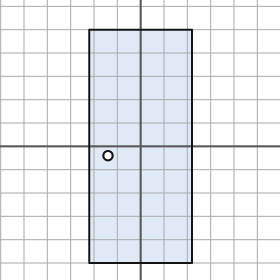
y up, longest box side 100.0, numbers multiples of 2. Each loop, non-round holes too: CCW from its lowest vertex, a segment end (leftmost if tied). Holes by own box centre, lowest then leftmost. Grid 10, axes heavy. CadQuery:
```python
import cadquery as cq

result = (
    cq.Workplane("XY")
    .moveTo(-22.0, -50.0)
    .lineTo(22.0, -50.0)
    .lineTo(22.0, 50.0)
    .lineTo(-22.0, 50.0)
    .close()
    .moveTo(-14.0, -4.0)
    .circle(2.0)
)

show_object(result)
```